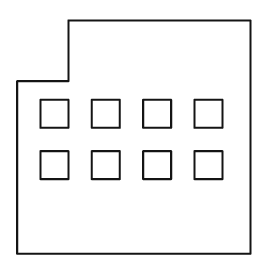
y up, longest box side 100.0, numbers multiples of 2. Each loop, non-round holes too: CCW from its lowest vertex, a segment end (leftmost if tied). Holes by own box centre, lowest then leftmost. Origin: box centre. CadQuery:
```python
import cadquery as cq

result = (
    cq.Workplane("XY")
    .moveTo(-50.0, -50.0)
    .lineTo(50.0, -50.0)
    .lineTo(50.0, 50.0)
    .lineTo(-28.0, 50.0)
    .lineTo(-28.0, 24.0)
    .lineTo(-50.0, 24.0)
    .close()
    .moveTo(-40.0, -18.0)
    .lineTo(-28.0, -18.0)
    .lineTo(-28.0, -6.0)
    .lineTo(-40.0, -6.0)
    .close()
    .moveTo(-18.0, -18.0)
    .lineTo(-6.0, -18.0)
    .lineTo(-6.0, -6.0)
    .lineTo(-18.0, -6.0)
    .close()
    .moveTo(4.0, -18.0)
    .lineTo(16.0, -18.0)
    .lineTo(16.0, -6.0)
    .lineTo(4.0, -6.0)
    .close()
    .moveTo(26.0, -18.0)
    .lineTo(38.0, -18.0)
    .lineTo(38.0, -6.0)
    .lineTo(26.0, -6.0)
    .close()
    .moveTo(-40.0, 4.0)
    .lineTo(-28.0, 4.0)
    .lineTo(-28.0, 16.0)
    .lineTo(-40.0, 16.0)
    .close()
    .moveTo(-18.0, 4.0)
    .lineTo(-6.0, 4.0)
    .lineTo(-6.0, 16.0)
    .lineTo(-18.0, 16.0)
    .close()
    .moveTo(4.0, 4.0)
    .lineTo(16.0, 4.0)
    .lineTo(16.0, 16.0)
    .lineTo(4.0, 16.0)
    .close()
    .moveTo(26.0, 4.0)
    .lineTo(38.0, 4.0)
    .lineTo(38.0, 16.0)
    .lineTo(26.0, 16.0)
    .close()
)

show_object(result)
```